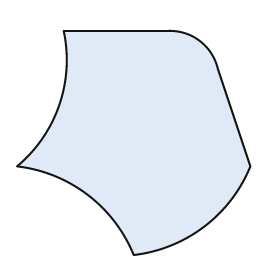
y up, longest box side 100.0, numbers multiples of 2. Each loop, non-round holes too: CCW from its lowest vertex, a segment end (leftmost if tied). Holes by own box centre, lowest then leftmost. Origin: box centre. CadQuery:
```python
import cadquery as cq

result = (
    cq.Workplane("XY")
    .moveTo(0.0, -48.0)
    .threePointArc((30.0, -36.0), (50.0, -10.0))
    .lineTo(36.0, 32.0)
    .threePointArc((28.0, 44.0), (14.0, 48.0))
    .lineTo(-30.0, 48.0)
    .threePointArc((-32.0, 16.0), (-50.0, -10.0))
    .threePointArc((-20.0, -22.0), (0.0, -48.0))
    .close()
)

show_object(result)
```